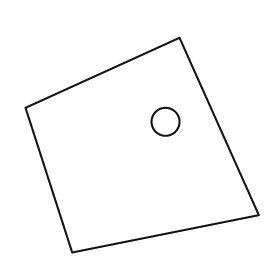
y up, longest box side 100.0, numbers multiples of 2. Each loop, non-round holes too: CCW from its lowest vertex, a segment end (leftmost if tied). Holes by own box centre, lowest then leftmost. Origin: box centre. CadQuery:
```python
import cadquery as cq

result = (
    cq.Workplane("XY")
    .moveTo(-30.0, -46.0)
    .lineTo(50.0, -30.0)
    .lineTo(16.0, 46.0)
    .lineTo(-50.0, 16.0)
    .close()
    .moveTo(10.0, 10.0)
    .circle(6.0)
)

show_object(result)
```